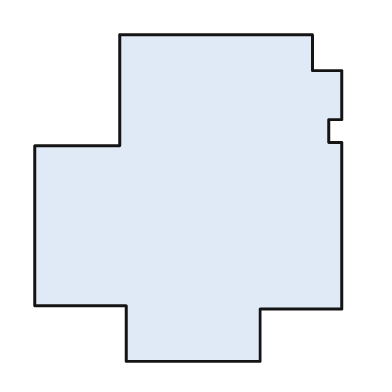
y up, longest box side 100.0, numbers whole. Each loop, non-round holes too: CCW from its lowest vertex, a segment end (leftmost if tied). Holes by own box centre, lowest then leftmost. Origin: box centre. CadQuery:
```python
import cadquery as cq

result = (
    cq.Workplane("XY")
    .moveTo(-19.0, -50.0)
    .lineTo(22.0, -50.0)
    .lineTo(22.0, -34.0)
    .lineTo(47.0, -34.0)
    .lineTo(47.0, 17.0)
    .lineTo(43.0, 17.0)
    .lineTo(43.0, 24.0)
    .lineTo(47.0, 24.0)
    .lineTo(47.0, 39.0)
    .lineTo(38.0, 39.0)
    .lineTo(38.0, 50.0)
    .lineTo(-21.0, 50.0)
    .lineTo(-21.0, 16.0)
    .lineTo(-47.0, 16.0)
    .lineTo(-47.0, -33.0)
    .lineTo(-19.0, -33.0)
    .close()
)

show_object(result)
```